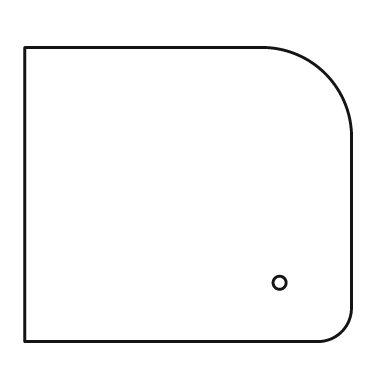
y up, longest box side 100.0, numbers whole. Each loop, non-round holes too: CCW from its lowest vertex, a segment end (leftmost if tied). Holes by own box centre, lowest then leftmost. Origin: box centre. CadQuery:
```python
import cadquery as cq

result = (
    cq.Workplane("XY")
    .moveTo(-50.0, -45.0)
    .lineTo(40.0, -45.0)
    .threePointArc((47.0, -42.0), (50.0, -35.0))
    .lineTo(50.0, 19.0)
    .threePointArc((42.0, 37.0), (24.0, 45.0))
    .lineTo(-50.0, 45.0)
    .close()
    .moveTo(28.0, -27.0)
    .circle(2.0)
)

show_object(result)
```